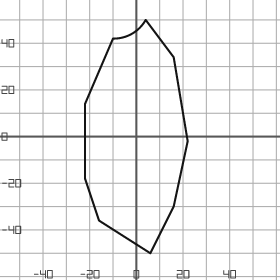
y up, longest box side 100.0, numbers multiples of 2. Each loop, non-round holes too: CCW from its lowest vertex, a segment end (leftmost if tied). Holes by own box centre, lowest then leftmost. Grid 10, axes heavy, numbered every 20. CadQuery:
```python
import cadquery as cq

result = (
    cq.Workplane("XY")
    .moveTo(6.0, -50.0)
    .lineTo(16.0, -30.0)
    .lineTo(22.0, -2.0)
    .lineTo(16.0, 34.0)
    .lineTo(4.0, 50.0)
    .threePointArc((-2.0, 44.0), (-10.0, 42.0))
    .lineTo(-22.0, 14.0)
    .lineTo(-22.0, -18.0)
    .lineTo(-16.0, -36.0)
    .close()
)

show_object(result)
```